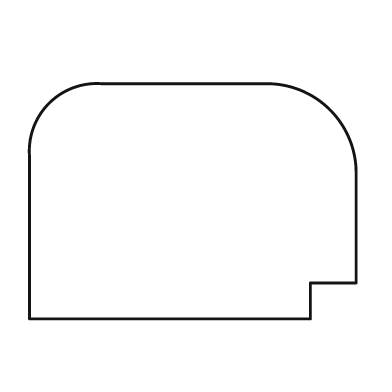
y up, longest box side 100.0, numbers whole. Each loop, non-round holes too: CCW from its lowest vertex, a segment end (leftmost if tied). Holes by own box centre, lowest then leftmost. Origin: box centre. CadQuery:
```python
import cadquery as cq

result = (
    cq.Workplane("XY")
    .moveTo(-50.0, -36.0)
    .lineTo(36.0, -36.0)
    .lineTo(36.0, -25.0)
    .lineTo(50.0, -25.0)
    .lineTo(50.0, 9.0)
    .threePointArc((42.0, 28.0), (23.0, 36.0))
    .lineTo(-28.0, 36.0)
    .threePointArc((-44.0, 30.0), (-50.0, 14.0))
    .close()
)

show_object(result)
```